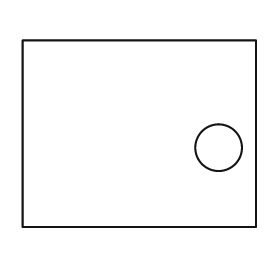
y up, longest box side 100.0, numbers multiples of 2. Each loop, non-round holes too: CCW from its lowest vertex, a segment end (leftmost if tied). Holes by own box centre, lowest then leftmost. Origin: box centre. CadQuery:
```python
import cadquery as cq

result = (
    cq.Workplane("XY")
    .moveTo(-50.0, -40.0)
    .lineTo(50.0, -40.0)
    .lineTo(50.0, 40.0)
    .lineTo(-50.0, 40.0)
    .close()
    .moveTo(34.0, -6.0)
    .circle(10.0)
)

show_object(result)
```